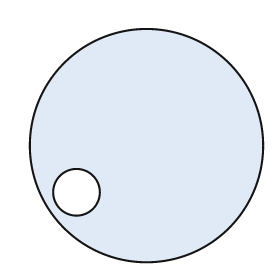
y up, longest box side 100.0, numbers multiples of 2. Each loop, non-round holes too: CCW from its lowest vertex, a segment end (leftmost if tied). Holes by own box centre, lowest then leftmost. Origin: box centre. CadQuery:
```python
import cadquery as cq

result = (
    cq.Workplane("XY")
    .moveTo(0.0, 0.0)
    .circle(50.0)
    .moveTo(-30.0, -20.0)
    .circle(10.0)
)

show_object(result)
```